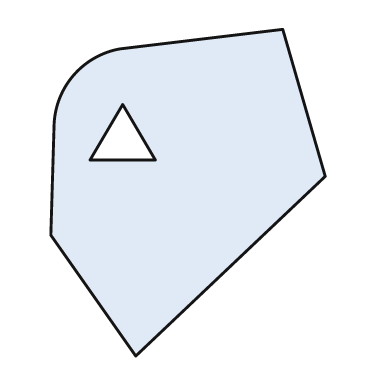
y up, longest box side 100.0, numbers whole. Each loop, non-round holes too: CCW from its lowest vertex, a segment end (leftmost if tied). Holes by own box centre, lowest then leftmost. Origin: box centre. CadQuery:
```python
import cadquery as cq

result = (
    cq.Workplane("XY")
    .moveTo(-16.0, -50.0)
    .lineTo(42.0, 5.0)
    .lineTo(29.0, 50.0)
    .lineTo(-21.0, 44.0)
    .threePointArc((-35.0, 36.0), (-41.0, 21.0))
    .lineTo(-42.0, -13.0)
    .close()
    .moveTo(-30.0, 10.0)
    .lineTo(-10.0, 10.0)
    .lineTo(-20.0, 27.0)
    .close()
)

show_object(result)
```